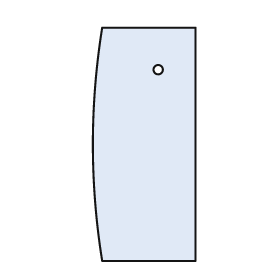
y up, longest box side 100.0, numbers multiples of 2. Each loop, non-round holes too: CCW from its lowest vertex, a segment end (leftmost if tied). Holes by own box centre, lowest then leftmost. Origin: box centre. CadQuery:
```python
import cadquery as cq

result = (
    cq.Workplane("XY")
    .moveTo(-18.0, -50.0)
    .lineTo(22.0, -50.0)
    .lineTo(22.0, 50.0)
    .lineTo(-18.0, 50.0)
    .threePointArc((-22.0, 0.0), (-18.0, -50.0))
    .close()
    .moveTo(6.0, 32.0)
    .circle(2.0)
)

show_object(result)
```